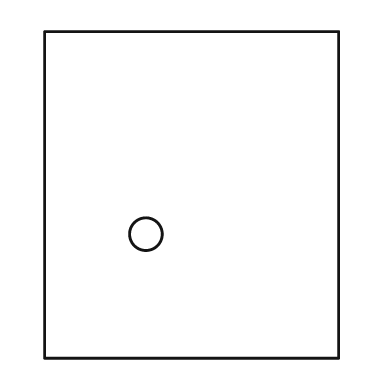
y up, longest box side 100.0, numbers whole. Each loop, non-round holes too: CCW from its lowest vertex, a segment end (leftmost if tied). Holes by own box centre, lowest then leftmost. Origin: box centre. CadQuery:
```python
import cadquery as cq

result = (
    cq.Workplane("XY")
    .moveTo(-45.0, -50.0)
    .lineTo(45.0, -50.0)
    .lineTo(45.0, 50.0)
    .lineTo(-45.0, 50.0)
    .close()
    .moveTo(-14.0, -12.0)
    .circle(5.0)
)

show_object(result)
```